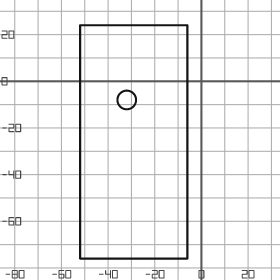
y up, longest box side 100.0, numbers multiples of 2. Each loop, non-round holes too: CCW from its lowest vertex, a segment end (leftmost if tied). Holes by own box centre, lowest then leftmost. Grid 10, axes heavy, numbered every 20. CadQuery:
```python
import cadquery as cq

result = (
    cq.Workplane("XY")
    .moveTo(-52.0, -76.0)
    .lineTo(-6.0, -76.0)
    .lineTo(-6.0, 24.0)
    .lineTo(-52.0, 24.0)
    .close()
    .moveTo(-32.0, -8.0)
    .circle(4.0)
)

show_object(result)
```